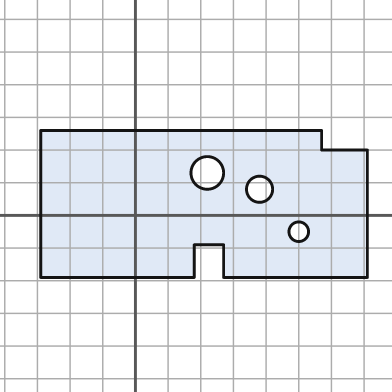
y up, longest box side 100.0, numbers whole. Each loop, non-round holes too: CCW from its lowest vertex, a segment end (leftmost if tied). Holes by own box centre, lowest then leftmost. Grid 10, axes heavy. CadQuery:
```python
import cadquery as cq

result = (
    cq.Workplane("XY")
    .moveTo(-29.0, -19.0)
    .lineTo(18.0, -19.0)
    .lineTo(18.0, -9.0)
    .lineTo(27.0, -9.0)
    .lineTo(27.0, -19.0)
    .lineTo(71.0, -19.0)
    .lineTo(71.0, 20.0)
    .lineTo(57.0, 20.0)
    .lineTo(57.0, 26.0)
    .lineTo(-29.0, 26.0)
    .close()
    .moveTo(50.0, -5.0)
    .circle(3.0)
    .moveTo(38.0, 8.0)
    .circle(4.0)
    .moveTo(22.0, 13.0)
    .circle(5.0)
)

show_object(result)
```